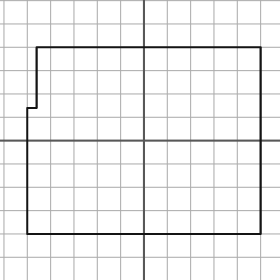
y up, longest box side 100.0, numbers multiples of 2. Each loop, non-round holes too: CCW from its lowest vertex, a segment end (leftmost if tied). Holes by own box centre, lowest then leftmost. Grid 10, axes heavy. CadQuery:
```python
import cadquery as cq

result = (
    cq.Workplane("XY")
    .moveTo(-50.0, -40.0)
    .lineTo(50.0, -40.0)
    .lineTo(50.0, 40.0)
    .lineTo(-46.0, 40.0)
    .lineTo(-46.0, 14.0)
    .lineTo(-50.0, 14.0)
    .close()
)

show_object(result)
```